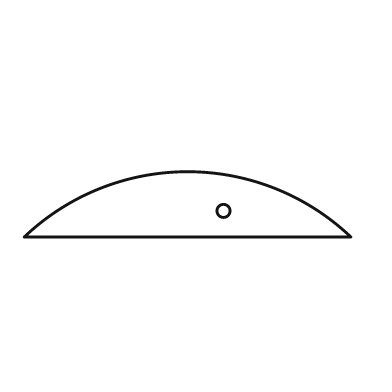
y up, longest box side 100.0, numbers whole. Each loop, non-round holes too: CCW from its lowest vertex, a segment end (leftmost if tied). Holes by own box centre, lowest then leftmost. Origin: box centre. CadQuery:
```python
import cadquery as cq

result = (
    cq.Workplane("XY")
    .moveTo(-50.0, -10.0)
    .lineTo(50.0, -10.0)
    .threePointArc((0.0, 10.0), (-50.0, -10.0))
    .close()
    .moveTo(11.0, -2.0)
    .circle(2.0)
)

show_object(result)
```